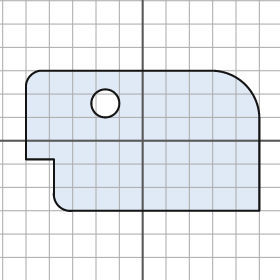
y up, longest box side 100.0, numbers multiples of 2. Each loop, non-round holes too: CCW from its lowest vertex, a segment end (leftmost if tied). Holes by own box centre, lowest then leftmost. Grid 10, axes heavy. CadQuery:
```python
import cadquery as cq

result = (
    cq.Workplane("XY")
    .moveTo(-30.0, -30.0)
    .lineTo(50.0, -30.0)
    .lineTo(50.0, 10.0)
    .threePointArc((44.0, 24.0), (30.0, 30.0))
    .lineTo(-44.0, 30.0)
    .threePointArc((-48.0, 28.0), (-50.0, 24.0))
    .lineTo(-50.0, -8.0)
    .lineTo(-38.0, -8.0)
    .lineTo(-38.0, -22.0)
    .threePointArc((-36.0, -28.0), (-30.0, -30.0))
    .close()
    .moveTo(-16.0, 16.0)
    .circle(6.0)
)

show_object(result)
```